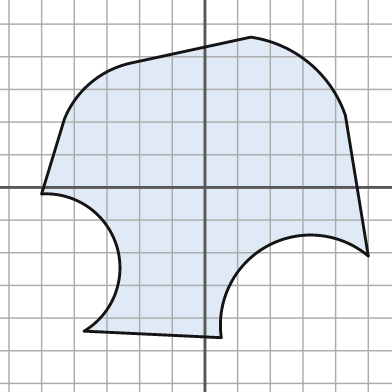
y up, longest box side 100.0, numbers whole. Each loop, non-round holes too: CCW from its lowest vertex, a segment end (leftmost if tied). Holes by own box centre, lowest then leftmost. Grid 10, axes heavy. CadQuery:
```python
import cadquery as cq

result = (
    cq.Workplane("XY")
    .moveTo(5.0, -46.0)
    .threePointArc((19.0, -18.0), (50.0, -21.0))
    .lineTo(43.0, 22.0)
    .threePointArc((32.0, 38.0), (14.0, 46.0))
    .lineTo(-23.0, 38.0)
    .threePointArc((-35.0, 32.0), (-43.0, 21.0))
    .lineTo(-50.0, -2.0)
    .threePointArc((-27.0, -18.0), (-37.0, -44.0))
    .close()
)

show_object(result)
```